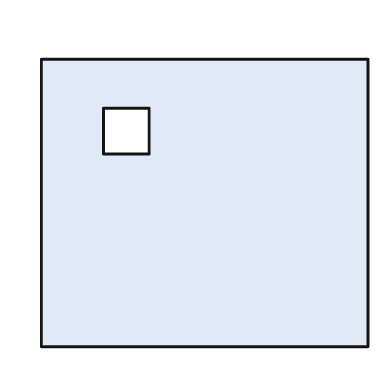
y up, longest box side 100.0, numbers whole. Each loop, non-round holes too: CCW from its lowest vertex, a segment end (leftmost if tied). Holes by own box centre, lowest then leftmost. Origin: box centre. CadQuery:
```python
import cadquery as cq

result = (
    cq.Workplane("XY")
    .moveTo(-50.0, -44.0)
    .lineTo(50.0, -44.0)
    .lineTo(50.0, 44.0)
    .lineTo(-50.0, 44.0)
    .close()
    .moveTo(-31.0, 15.0)
    .lineTo(-17.0, 15.0)
    .lineTo(-17.0, 29.0)
    .lineTo(-31.0, 29.0)
    .close()
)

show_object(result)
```